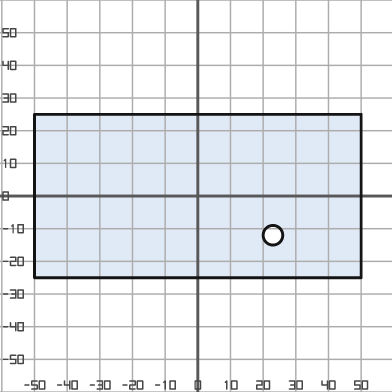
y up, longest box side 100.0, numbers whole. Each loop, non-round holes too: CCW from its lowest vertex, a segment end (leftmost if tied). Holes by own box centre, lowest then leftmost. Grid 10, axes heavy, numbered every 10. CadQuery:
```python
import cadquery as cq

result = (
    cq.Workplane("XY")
    .moveTo(-50.0, -25.0)
    .lineTo(50.0, -25.0)
    .lineTo(50.0, 25.0)
    .lineTo(-50.0, 25.0)
    .close()
    .moveTo(23.0, -12.0)
    .circle(3.0)
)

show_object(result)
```